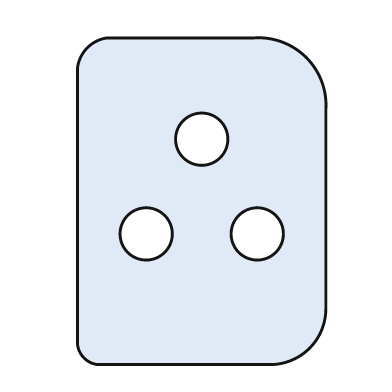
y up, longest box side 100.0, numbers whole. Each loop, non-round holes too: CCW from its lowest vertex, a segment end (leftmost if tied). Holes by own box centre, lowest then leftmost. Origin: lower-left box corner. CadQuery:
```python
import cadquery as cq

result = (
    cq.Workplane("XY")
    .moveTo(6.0, 0.0)
    .lineTo(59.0, 0.0)
    .threePointArc((71.0, 5.0), (76.0, 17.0))
    .lineTo(76.0, 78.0)
    .threePointArc((70.0, 94.0), (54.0, 100.0))
    .lineTo(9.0, 100.0)
    .threePointArc((3.0, 97.0), (0.0, 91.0))
    .lineTo(0.0, 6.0)
    .threePointArc((2.0, 2.0), (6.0, 0.0))
    .close()
    .moveTo(21.0, 40.0)
    .circle(8.0)
    .moveTo(55.0, 40.0)
    .circle(8.0)
    .moveTo(38.0, 69.0)
    .circle(8.0)
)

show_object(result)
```